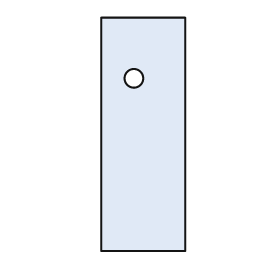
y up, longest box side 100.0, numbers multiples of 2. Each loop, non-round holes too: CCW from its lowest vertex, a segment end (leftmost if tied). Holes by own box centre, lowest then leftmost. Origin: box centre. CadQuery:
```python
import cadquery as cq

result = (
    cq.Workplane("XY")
    .moveTo(-18.0, -50.0)
    .lineTo(18.0, -50.0)
    .lineTo(18.0, 50.0)
    .lineTo(-18.0, 50.0)
    .close()
    .moveTo(-4.0, 24.0)
    .circle(4.0)
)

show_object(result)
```